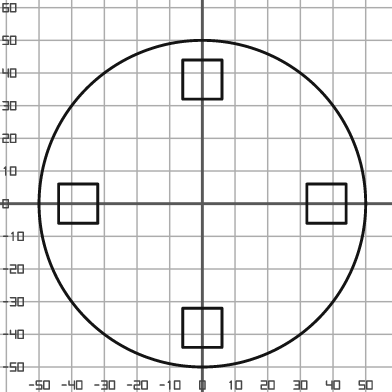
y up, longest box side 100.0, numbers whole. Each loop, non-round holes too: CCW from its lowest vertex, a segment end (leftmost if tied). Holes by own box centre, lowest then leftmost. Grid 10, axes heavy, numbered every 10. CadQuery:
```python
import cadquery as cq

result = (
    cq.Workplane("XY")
    .moveTo(0.0, 0.0)
    .circle(50.0)
    .moveTo(-6.0, -44.0)
    .lineTo(6.0, -44.0)
    .lineTo(6.0, -32.0)
    .lineTo(-6.0, -32.0)
    .close()
    .moveTo(-44.0, -6.0)
    .lineTo(-32.0, -6.0)
    .lineTo(-32.0, 6.0)
    .lineTo(-44.0, 6.0)
    .close()
    .moveTo(32.0, -6.0)
    .lineTo(44.0, -6.0)
    .lineTo(44.0, 6.0)
    .lineTo(32.0, 6.0)
    .close()
    .moveTo(-6.0, 32.0)
    .lineTo(6.0, 32.0)
    .lineTo(6.0, 44.0)
    .lineTo(-6.0, 44.0)
    .close()
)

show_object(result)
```